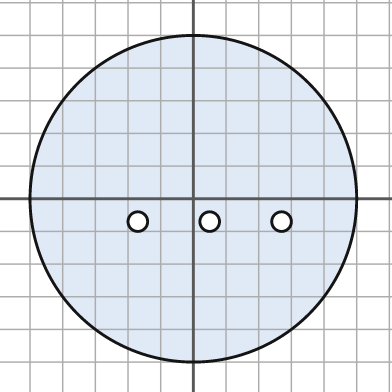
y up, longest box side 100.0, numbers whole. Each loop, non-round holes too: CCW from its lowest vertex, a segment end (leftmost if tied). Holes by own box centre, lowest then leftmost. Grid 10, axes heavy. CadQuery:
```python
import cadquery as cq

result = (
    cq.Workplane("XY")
    .moveTo(0.0, 0.0)
    .circle(50.0)
    .moveTo(-17.0, -7.0)
    .circle(3.0)
    .moveTo(5.0, -7.0)
    .circle(3.0)
    .moveTo(27.0, -7.0)
    .circle(3.0)
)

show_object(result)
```